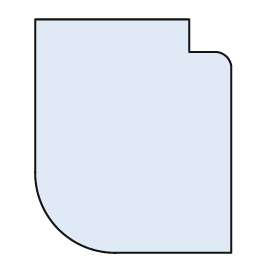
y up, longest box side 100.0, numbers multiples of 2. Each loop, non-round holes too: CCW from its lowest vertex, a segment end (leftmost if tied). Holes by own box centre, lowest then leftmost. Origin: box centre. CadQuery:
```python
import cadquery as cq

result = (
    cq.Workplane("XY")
    .moveTo(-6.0, -50.0)
    .lineTo(42.0, -50.0)
    .lineTo(42.0, 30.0)
    .threePointArc((40.0, 34.0), (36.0, 36.0))
    .lineTo(24.0, 36.0)
    .lineTo(24.0, 50.0)
    .lineTo(-42.0, 50.0)
    .lineTo(-42.0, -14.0)
    .threePointArc((-32.0, -40.0), (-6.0, -50.0))
    .close()
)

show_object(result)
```